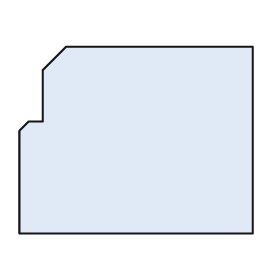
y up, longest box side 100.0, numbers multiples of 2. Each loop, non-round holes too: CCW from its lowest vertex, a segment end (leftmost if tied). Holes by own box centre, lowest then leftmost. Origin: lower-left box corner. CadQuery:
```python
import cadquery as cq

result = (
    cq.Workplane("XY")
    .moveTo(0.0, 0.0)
    .lineTo(100.0, 0.0)
    .lineTo(100.0, 80.0)
    .lineTo(20.0, 80.0)
    .lineTo(10.0, 70.0)
    .lineTo(10.0, 48.0)
    .lineTo(4.0, 48.0)
    .lineTo(0.0, 44.0)
    .close()
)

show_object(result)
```